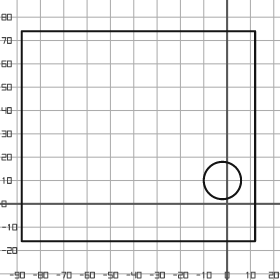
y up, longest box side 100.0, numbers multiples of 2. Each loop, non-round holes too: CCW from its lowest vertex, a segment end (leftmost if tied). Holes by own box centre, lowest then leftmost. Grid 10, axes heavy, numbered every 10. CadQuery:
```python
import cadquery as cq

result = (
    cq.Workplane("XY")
    .moveTo(-88.0, -16.0)
    .lineTo(12.0, -16.0)
    .lineTo(12.0, 74.0)
    .lineTo(-88.0, 74.0)
    .close()
    .moveTo(-2.0, 10.0)
    .circle(8.0)
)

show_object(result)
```